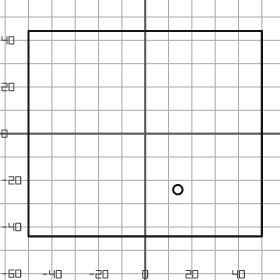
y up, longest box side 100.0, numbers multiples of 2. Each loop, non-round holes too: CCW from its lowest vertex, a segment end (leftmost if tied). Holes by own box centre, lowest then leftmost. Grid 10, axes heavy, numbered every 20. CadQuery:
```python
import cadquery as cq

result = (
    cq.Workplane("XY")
    .moveTo(-50.0, -44.0)
    .lineTo(50.0, -44.0)
    .lineTo(50.0, 44.0)
    .lineTo(-50.0, 44.0)
    .close()
    .moveTo(14.0, -24.0)
    .circle(2.0)
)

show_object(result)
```